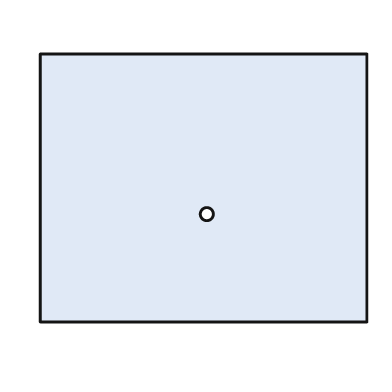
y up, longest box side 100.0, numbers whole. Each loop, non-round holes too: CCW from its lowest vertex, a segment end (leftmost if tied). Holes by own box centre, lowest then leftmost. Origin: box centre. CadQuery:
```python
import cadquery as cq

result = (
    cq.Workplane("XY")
    .moveTo(-50.0, -41.0)
    .lineTo(50.0, -41.0)
    .lineTo(50.0, 41.0)
    .lineTo(-50.0, 41.0)
    .close()
    .moveTo(1.0, -8.0)
    .circle(2.0)
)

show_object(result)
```